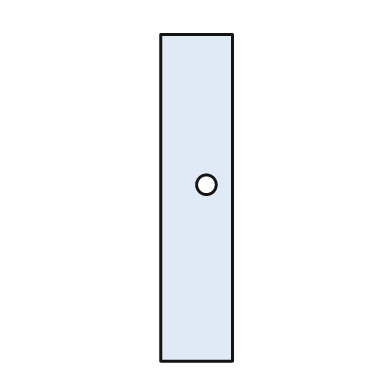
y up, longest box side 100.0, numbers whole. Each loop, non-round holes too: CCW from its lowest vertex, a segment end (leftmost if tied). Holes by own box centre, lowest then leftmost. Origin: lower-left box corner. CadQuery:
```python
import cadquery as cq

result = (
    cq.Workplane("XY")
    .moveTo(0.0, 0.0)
    .lineTo(22.0, 0.0)
    .lineTo(22.0, 100.0)
    .lineTo(0.0, 100.0)
    .close()
    .moveTo(14.0, 54.0)
    .circle(3.0)
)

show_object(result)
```